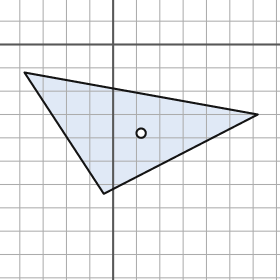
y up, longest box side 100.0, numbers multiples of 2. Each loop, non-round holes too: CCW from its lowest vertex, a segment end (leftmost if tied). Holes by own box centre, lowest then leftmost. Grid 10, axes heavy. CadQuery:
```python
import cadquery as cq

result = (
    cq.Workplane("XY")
    .moveTo(-4.0, -64.0)
    .lineTo(62.0, -30.0)
    .lineTo(-38.0, -12.0)
    .close()
    .moveTo(12.0, -38.0)
    .circle(2.0)
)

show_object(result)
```